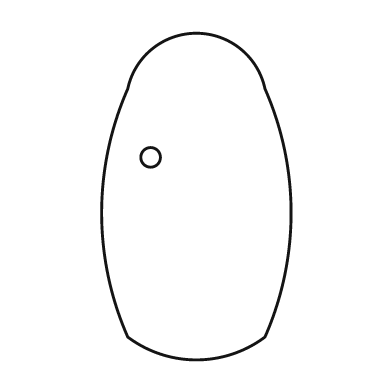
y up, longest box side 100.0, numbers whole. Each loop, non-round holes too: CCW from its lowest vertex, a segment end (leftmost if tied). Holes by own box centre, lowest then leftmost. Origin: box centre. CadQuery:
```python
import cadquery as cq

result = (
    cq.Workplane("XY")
    .moveTo(-21.0, -43.0)
    .threePointArc((0.0, -50.0), (21.0, -43.0))
    .threePointArc((29.0, -5.0), (21.0, 33.0))
    .threePointArc((0.0, 50.0), (-21.0, 33.0))
    .threePointArc((-29.0, -5.0), (-21.0, -43.0))
    .close()
    .moveTo(-14.0, 12.0)
    .circle(3.0)
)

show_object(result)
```